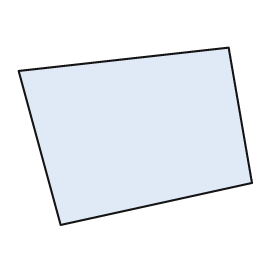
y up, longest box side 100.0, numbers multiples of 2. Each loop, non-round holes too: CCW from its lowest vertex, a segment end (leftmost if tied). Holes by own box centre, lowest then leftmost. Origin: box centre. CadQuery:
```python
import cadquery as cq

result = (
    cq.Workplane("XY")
    .moveTo(-32.0, -38.0)
    .lineTo(50.0, -20.0)
    .lineTo(40.0, 38.0)
    .lineTo(-50.0, 28.0)
    .close()
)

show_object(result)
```